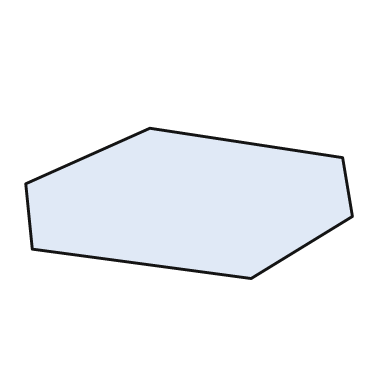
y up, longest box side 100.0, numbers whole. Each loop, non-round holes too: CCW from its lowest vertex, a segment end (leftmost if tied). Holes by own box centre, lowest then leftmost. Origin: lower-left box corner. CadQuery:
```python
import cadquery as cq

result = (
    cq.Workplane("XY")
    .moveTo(69.0, 0.0)
    .lineTo(100.0, 19.0)
    .lineTo(97.0, 37.0)
    .lineTo(38.0, 46.0)
    .lineTo(0.0, 29.0)
    .lineTo(2.0, 9.0)
    .close()
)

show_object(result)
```